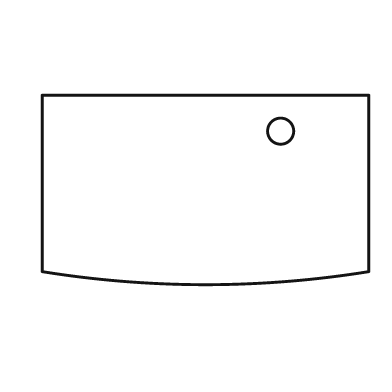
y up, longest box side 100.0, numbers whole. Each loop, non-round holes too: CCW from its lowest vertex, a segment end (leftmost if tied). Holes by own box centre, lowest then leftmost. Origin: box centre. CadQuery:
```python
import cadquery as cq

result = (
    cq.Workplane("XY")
    .moveTo(-50.0, -25.0)
    .threePointArc((0.0, -29.0), (50.0, -25.0))
    .lineTo(50.0, 29.0)
    .lineTo(-50.0, 29.0)
    .close()
    .moveTo(23.0, 18.0)
    .circle(4.0)
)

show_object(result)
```